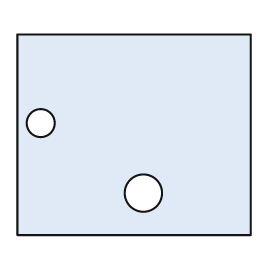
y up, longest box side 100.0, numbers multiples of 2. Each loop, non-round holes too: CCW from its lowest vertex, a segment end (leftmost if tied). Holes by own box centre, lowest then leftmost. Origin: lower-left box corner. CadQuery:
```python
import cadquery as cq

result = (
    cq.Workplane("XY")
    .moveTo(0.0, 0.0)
    .lineTo(100.0, 0.0)
    .lineTo(100.0, 86.0)
    .lineTo(0.0, 86.0)
    .close()
    .moveTo(54.0, 18.0)
    .circle(8.0)
    .moveTo(10.0, 48.0)
    .circle(6.0)
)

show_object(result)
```